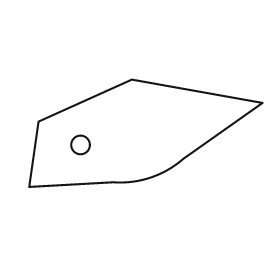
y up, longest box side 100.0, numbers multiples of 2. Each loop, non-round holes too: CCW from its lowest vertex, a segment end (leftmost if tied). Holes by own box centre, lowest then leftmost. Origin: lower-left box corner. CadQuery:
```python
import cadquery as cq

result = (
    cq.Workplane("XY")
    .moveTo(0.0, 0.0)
    .lineTo(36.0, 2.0)
    .threePointArc((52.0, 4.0), (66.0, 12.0))
    .lineTo(100.0, 36.0)
    .lineTo(44.0, 46.0)
    .lineTo(4.0, 28.0)
    .close()
    .moveTo(22.0, 18.0)
    .circle(4.0)
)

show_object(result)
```